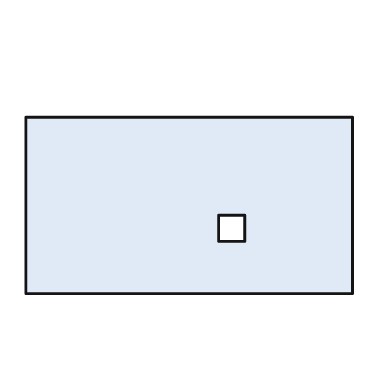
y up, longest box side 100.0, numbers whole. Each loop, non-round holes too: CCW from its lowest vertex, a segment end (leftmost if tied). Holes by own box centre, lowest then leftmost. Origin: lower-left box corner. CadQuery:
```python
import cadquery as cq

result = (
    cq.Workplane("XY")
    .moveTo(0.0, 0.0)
    .lineTo(100.0, 0.0)
    .lineTo(100.0, 54.0)
    .lineTo(0.0, 54.0)
    .close()
    .moveTo(59.0, 16.0)
    .lineTo(67.0, 16.0)
    .lineTo(67.0, 24.0)
    .lineTo(59.0, 24.0)
    .close()
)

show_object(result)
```